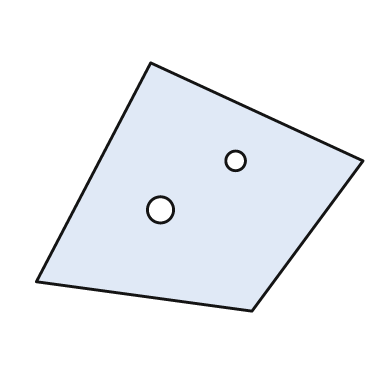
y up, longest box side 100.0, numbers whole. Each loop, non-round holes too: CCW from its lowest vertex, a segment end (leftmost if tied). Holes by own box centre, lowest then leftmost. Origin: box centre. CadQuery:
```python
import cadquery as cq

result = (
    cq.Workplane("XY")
    .moveTo(16.0, -38.0)
    .lineTo(50.0, 8.0)
    .lineTo(-15.0, 38.0)
    .lineTo(-50.0, -29.0)
    .close()
    .moveTo(-12.0, -7.0)
    .circle(4.0)
    .moveTo(11.0, 8.0)
    .circle(3.0)
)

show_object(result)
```